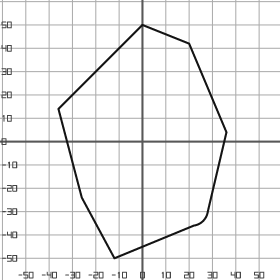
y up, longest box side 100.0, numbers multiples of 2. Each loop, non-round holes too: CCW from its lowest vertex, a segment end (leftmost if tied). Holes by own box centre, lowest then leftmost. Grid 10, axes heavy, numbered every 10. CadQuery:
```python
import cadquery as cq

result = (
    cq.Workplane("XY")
    .moveTo(-12.0, -50.0)
    .lineTo(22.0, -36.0)
    .threePointArc((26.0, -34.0), (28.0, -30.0))
    .lineTo(36.0, 4.0)
    .lineTo(20.0, 42.0)
    .lineTo(0.0, 50.0)
    .lineTo(-36.0, 14.0)
    .lineTo(-26.0, -24.0)
    .close()
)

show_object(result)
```